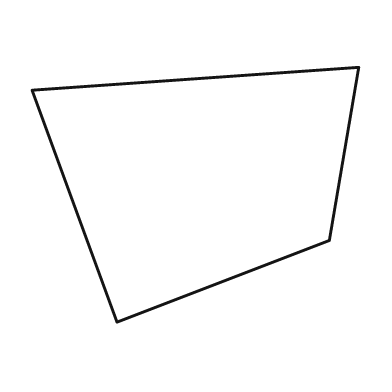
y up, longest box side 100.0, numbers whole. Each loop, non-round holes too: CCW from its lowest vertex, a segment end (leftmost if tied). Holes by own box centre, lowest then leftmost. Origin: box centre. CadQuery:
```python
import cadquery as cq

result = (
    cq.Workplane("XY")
    .moveTo(-24.0, -39.0)
    .lineTo(41.0, -14.0)
    .lineTo(50.0, 39.0)
    .lineTo(-50.0, 32.0)
    .close()
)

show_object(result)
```